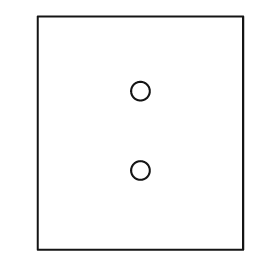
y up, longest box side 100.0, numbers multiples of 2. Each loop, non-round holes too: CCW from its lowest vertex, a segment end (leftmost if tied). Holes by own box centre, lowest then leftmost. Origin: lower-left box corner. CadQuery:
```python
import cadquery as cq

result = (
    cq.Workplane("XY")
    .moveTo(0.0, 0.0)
    .lineTo(88.0, 0.0)
    .lineTo(88.0, 100.0)
    .lineTo(0.0, 100.0)
    .close()
    .moveTo(44.0, 34.0)
    .circle(4.0)
    .moveTo(44.0, 68.0)
    .circle(4.0)
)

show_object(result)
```